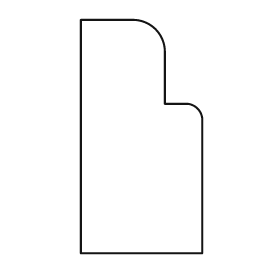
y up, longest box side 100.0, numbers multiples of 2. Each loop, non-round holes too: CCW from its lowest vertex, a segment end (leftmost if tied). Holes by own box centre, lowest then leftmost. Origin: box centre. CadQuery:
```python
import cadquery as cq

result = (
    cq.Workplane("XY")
    .moveTo(-26.0, -50.0)
    .lineTo(26.0, -50.0)
    .lineTo(26.0, 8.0)
    .threePointArc((24.0, 12.0), (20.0, 14.0))
    .lineTo(10.0, 14.0)
    .lineTo(10.0, 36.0)
    .threePointArc((6.0, 46.0), (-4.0, 50.0))
    .lineTo(-26.0, 50.0)
    .close()
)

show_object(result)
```